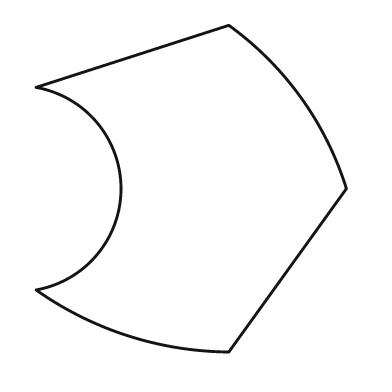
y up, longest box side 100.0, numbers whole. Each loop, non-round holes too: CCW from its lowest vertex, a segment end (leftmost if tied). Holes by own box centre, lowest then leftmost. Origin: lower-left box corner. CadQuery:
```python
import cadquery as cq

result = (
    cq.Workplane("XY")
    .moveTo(59.0, 0.0)
    .lineTo(95.0, 50.0)
    .threePointArc((81.0, 78.0), (59.0, 100.0))
    .lineTo(0.0, 81.0)
    .threePointArc((26.0, 50.0), (0.0, 19.0))
    .threePointArc((28.0, 5.0), (59.0, 0.0))
    .close()
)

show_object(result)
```